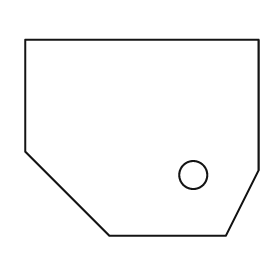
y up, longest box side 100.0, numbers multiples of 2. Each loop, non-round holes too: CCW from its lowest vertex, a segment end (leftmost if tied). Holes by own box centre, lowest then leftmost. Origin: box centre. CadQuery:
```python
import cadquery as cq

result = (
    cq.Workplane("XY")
    .moveTo(-14.0, -42.0)
    .lineTo(36.0, -42.0)
    .lineTo(50.0, -14.0)
    .lineTo(50.0, 42.0)
    .lineTo(-50.0, 42.0)
    .lineTo(-50.0, -6.0)
    .close()
    .moveTo(22.0, -16.0)
    .circle(6.0)
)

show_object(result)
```